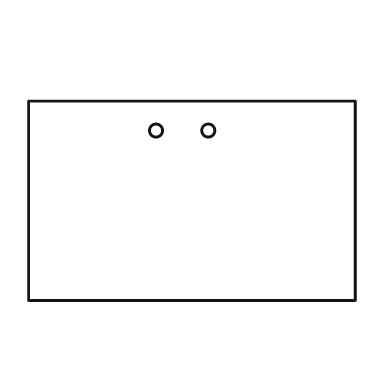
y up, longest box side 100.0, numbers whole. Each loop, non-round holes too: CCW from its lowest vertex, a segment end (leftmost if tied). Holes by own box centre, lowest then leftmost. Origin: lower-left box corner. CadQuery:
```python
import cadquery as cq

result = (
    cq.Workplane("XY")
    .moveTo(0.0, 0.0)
    .lineTo(100.0, 0.0)
    .lineTo(100.0, 61.0)
    .lineTo(0.0, 61.0)
    .close()
    .moveTo(39.0, 52.0)
    .circle(2.0)
    .moveTo(55.0, 52.0)
    .circle(2.0)
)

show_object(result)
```